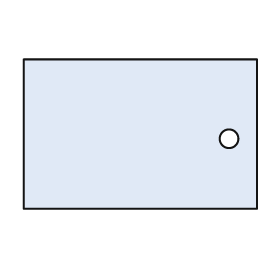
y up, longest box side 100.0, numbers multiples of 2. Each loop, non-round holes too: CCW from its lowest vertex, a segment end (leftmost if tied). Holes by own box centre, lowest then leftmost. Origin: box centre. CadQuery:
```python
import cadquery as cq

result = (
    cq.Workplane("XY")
    .moveTo(-50.0, -32.0)
    .lineTo(50.0, -32.0)
    .lineTo(50.0, 32.0)
    .lineTo(-50.0, 32.0)
    .close()
    .moveTo(38.0, -2.0)
    .circle(4.0)
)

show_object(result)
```